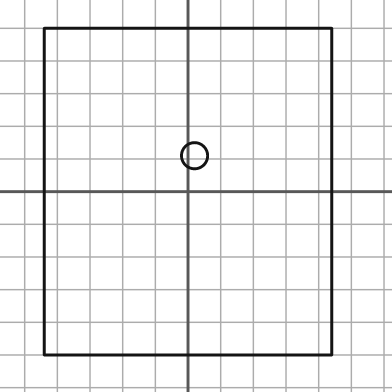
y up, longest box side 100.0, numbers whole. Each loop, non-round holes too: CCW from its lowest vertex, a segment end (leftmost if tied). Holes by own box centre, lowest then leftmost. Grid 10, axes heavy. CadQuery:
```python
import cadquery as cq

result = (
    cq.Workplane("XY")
    .moveTo(-44.0, -50.0)
    .lineTo(44.0, -50.0)
    .lineTo(44.0, 50.0)
    .lineTo(-44.0, 50.0)
    .close()
    .moveTo(2.0, 11.0)
    .circle(4.0)
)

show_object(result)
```